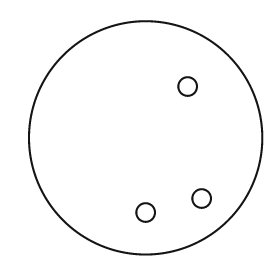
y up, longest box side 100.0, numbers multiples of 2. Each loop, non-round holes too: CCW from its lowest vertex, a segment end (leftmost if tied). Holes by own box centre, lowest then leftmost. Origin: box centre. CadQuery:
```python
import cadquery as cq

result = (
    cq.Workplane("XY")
    .moveTo(0.0, 0.0)
    .circle(50.0)
    .moveTo(0.0, -32.0)
    .circle(4.0)
    .moveTo(24.0, -26.0)
    .circle(4.0)
    .moveTo(18.0, 22.0)
    .circle(4.0)
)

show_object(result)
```